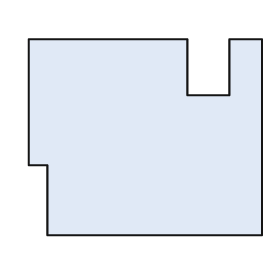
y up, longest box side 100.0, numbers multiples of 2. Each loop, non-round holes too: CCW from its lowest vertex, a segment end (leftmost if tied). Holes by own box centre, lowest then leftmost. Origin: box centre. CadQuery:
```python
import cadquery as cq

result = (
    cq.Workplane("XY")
    .moveTo(-42.0, -42.0)
    .lineTo(50.0, -42.0)
    .lineTo(50.0, 42.0)
    .lineTo(36.0, 42.0)
    .lineTo(36.0, 18.0)
    .lineTo(18.0, 18.0)
    .lineTo(18.0, 42.0)
    .lineTo(-50.0, 42.0)
    .lineTo(-50.0, -12.0)
    .lineTo(-42.0, -12.0)
    .close()
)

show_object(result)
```